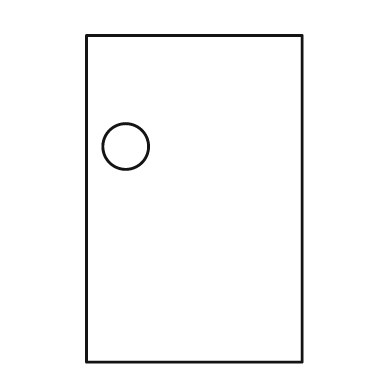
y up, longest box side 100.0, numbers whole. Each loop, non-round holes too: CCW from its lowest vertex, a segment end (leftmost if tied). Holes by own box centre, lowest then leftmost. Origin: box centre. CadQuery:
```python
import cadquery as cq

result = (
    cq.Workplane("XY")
    .moveTo(-33.0, -50.0)
    .lineTo(33.0, -50.0)
    .lineTo(33.0, 50.0)
    .lineTo(-33.0, 50.0)
    .close()
    .moveTo(-21.0, 16.0)
    .circle(7.0)
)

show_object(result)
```